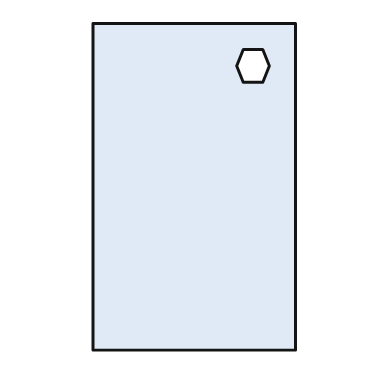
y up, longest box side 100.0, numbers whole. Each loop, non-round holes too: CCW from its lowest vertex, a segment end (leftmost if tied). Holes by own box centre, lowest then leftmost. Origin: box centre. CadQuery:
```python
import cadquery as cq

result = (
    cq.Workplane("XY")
    .moveTo(-31.0, -50.0)
    .lineTo(31.0, -50.0)
    .lineTo(31.0, 50.0)
    .lineTo(-31.0, 50.0)
    .close()
    .moveTo(15.0, 32.0)
    .lineTo(21.0, 32.0)
    .lineTo(23.0, 37.0)
    .lineTo(21.0, 42.0)
    .lineTo(15.0, 42.0)
    .lineTo(13.0, 37.0)
    .close()
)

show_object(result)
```